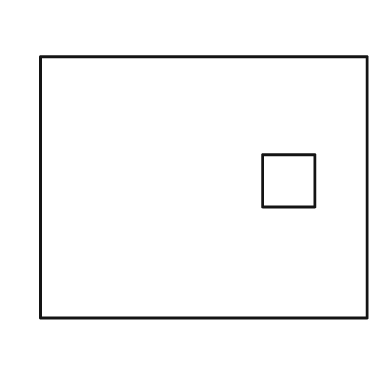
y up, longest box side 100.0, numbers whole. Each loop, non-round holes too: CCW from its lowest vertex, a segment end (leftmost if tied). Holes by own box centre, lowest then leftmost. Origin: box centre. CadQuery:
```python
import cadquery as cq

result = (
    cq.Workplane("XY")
    .moveTo(-50.0, -40.0)
    .lineTo(50.0, -40.0)
    .lineTo(50.0, 40.0)
    .lineTo(-50.0, 40.0)
    .close()
    .moveTo(18.0, -6.0)
    .lineTo(34.0, -6.0)
    .lineTo(34.0, 10.0)
    .lineTo(18.0, 10.0)
    .close()
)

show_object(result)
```